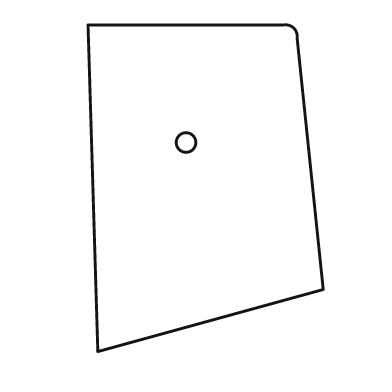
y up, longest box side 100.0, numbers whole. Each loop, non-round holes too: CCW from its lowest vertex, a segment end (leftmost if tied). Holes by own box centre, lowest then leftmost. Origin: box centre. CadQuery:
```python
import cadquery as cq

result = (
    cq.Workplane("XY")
    .moveTo(-33.0, -50.0)
    .lineTo(36.0, -31.0)
    .lineTo(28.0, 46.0)
    .threePointArc((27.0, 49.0), (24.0, 50.0))
    .lineTo(-36.0, 50.0)
    .close()
    .moveTo(-6.0, 14.0)
    .circle(3.0)
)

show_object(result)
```